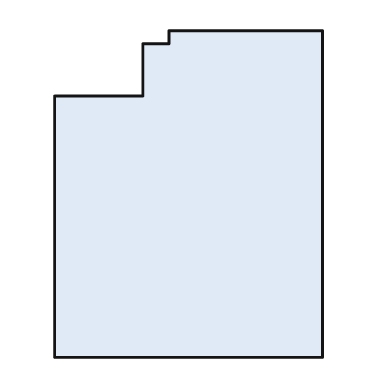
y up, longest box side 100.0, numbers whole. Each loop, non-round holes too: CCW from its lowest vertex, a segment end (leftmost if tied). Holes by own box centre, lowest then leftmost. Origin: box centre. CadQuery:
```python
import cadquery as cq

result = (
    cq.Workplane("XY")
    .moveTo(-41.0, -50.0)
    .lineTo(41.0, -50.0)
    .lineTo(41.0, 50.0)
    .lineTo(-6.0, 50.0)
    .lineTo(-6.0, 46.0)
    .lineTo(-14.0, 46.0)
    .lineTo(-14.0, 30.0)
    .lineTo(-41.0, 30.0)
    .close()
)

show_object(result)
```